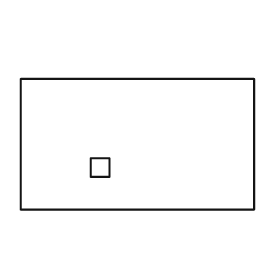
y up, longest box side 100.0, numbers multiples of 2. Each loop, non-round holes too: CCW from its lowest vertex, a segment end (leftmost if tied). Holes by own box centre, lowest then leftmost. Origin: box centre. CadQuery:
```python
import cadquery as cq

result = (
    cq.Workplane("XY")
    .moveTo(-50.0, -28.0)
    .lineTo(50.0, -28.0)
    .lineTo(50.0, 28.0)
    .lineTo(-50.0, 28.0)
    .close()
    .moveTo(-20.0, -14.0)
    .lineTo(-12.0, -14.0)
    .lineTo(-12.0, -6.0)
    .lineTo(-20.0, -6.0)
    .close()
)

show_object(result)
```